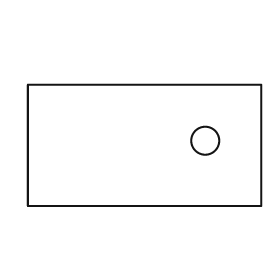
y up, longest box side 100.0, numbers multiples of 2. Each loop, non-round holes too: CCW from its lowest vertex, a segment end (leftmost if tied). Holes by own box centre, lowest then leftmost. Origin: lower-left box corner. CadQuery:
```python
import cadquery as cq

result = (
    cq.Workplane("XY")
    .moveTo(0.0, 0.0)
    .lineTo(100.0, 0.0)
    .lineTo(100.0, 52.0)
    .lineTo(0.0, 52.0)
    .close()
    .moveTo(76.0, 28.0)
    .circle(6.0)
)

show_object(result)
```